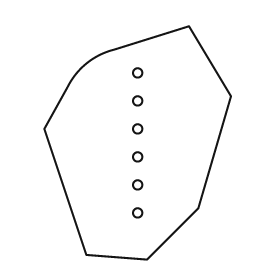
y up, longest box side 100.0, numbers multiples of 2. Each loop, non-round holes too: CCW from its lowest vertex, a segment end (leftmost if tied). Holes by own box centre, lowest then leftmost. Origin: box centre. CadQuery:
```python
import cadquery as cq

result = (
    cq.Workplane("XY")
    .moveTo(4.0, -50.0)
    .lineTo(26.0, -28.0)
    .lineTo(40.0, 20.0)
    .lineTo(22.0, 50.0)
    .lineTo(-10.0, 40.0)
    .threePointArc((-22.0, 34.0), (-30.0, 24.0))
    .lineTo(-40.0, 6.0)
    .lineTo(-22.0, -48.0)
    .close()
    .moveTo(0.0, -30.0)
    .circle(2.0)
    .moveTo(0.0, -18.0)
    .circle(2.0)
    .moveTo(0.0, -6.0)
    .circle(2.0)
    .moveTo(0.0, 6.0)
    .circle(2.0)
    .moveTo(0.0, 18.0)
    .circle(2.0)
    .moveTo(0.0, 30.0)
    .circle(2.0)
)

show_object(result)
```